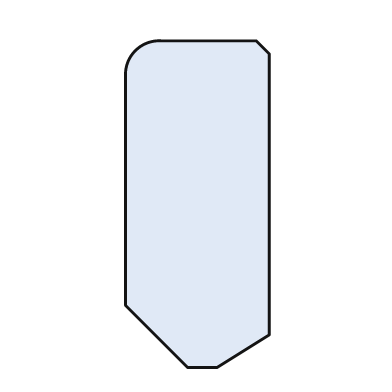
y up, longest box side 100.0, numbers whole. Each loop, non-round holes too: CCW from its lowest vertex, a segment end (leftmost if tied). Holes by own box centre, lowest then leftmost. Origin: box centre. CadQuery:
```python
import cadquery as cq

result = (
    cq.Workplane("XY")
    .moveTo(-3.0, -50.0)
    .lineTo(6.0, -50.0)
    .lineTo(22.0, -40.0)
    .lineTo(22.0, 46.0)
    .lineTo(18.0, 50.0)
    .lineTo(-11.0, 50.0)
    .threePointArc((-19.0, 47.0), (-22.0, 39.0))
    .lineTo(-22.0, -31.0)
    .close()
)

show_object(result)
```